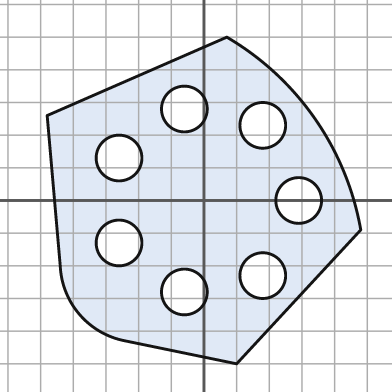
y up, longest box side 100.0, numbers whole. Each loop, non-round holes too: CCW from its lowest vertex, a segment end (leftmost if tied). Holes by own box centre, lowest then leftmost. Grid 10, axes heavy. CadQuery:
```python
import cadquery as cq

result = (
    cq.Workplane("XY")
    .moveTo(10.0, -50.0)
    .lineTo(48.0, -9.0)
    .threePointArc((34.0, 25.0), (7.0, 50.0))
    .lineTo(-48.0, 26.0)
    .lineTo(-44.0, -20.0)
    .threePointArc((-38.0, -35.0), (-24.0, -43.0))
    .close()
    .moveTo(-6.0, -28.0)
    .circle(7.0)
    .moveTo(18.0, -23.0)
    .circle(7.0)
    .moveTo(-26.0, -13.0)
    .circle(7.0)
    .moveTo(29.0, 0.0)
    .circle(7.0)
    .moveTo(-26.0, 13.0)
    .circle(7.0)
    .moveTo(18.0, 23.0)
    .circle(7.0)
    .moveTo(-6.0, 28.0)
    .circle(7.0)
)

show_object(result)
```